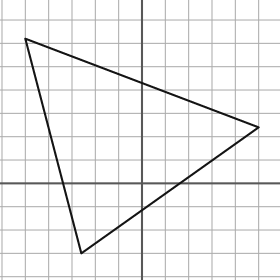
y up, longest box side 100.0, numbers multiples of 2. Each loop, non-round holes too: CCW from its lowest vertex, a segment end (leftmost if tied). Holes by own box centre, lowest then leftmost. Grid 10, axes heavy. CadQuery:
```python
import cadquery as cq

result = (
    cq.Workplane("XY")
    .moveTo(-26.0, -30.0)
    .lineTo(50.0, 24.0)
    .lineTo(-50.0, 62.0)
    .close()
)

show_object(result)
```